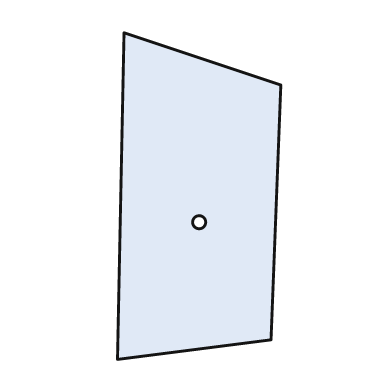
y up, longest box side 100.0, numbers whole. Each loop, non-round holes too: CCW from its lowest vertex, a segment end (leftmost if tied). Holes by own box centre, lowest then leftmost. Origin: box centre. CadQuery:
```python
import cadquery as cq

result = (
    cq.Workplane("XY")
    .moveTo(-25.0, -50.0)
    .lineTo(22.0, -44.0)
    .lineTo(25.0, 34.0)
    .lineTo(-23.0, 50.0)
    .close()
    .moveTo(0.0, -8.0)
    .circle(2.0)
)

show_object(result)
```